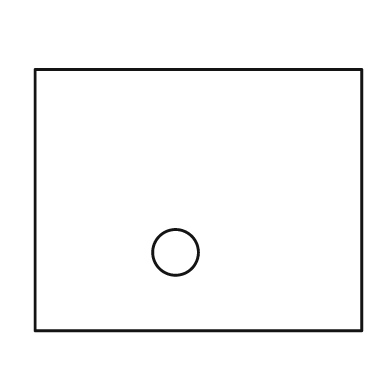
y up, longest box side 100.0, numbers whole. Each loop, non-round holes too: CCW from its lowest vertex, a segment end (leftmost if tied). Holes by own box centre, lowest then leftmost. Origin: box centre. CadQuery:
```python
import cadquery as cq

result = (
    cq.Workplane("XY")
    .moveTo(-50.0, -40.0)
    .lineTo(50.0, -40.0)
    .lineTo(50.0, 40.0)
    .lineTo(-50.0, 40.0)
    .close()
    .moveTo(-7.0, -16.0)
    .circle(7.0)
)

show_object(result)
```